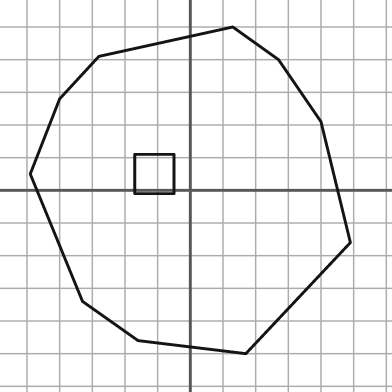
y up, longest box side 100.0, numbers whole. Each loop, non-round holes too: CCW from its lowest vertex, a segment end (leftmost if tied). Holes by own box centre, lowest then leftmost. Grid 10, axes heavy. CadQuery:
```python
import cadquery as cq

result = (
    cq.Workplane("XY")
    .moveTo(17.0, -50.0)
    .lineTo(49.0, -16.0)
    .lineTo(40.0, 21.0)
    .lineTo(27.0, 40.0)
    .lineTo(13.0, 50.0)
    .lineTo(-28.0, 41.0)
    .lineTo(-40.0, 28.0)
    .lineTo(-49.0, 5.0)
    .lineTo(-33.0, -34.0)
    .lineTo(-16.0, -46.0)
    .close()
    .moveTo(-17.0, -1.0)
    .lineTo(-5.0, -1.0)
    .lineTo(-5.0, 11.0)
    .lineTo(-17.0, 11.0)
    .close()
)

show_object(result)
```